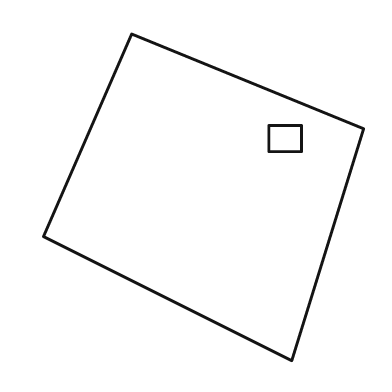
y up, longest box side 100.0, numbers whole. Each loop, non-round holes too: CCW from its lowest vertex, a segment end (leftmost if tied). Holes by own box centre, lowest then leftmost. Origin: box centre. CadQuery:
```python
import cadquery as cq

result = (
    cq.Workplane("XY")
    .moveTo(27.0, -50.0)
    .lineTo(49.0, 21.0)
    .lineTo(-22.0, 50.0)
    .lineTo(-49.0, -12.0)
    .close()
    .moveTo(20.0, 14.0)
    .lineTo(30.0, 14.0)
    .lineTo(30.0, 22.0)
    .lineTo(20.0, 22.0)
    .close()
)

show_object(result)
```